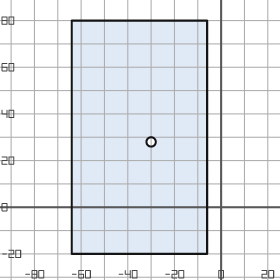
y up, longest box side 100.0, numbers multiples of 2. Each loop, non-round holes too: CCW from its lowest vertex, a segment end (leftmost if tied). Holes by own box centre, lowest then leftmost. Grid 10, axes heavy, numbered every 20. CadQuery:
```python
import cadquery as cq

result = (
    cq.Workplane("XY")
    .moveTo(-64.0, -20.0)
    .lineTo(-6.0, -20.0)
    .lineTo(-6.0, 80.0)
    .lineTo(-64.0, 80.0)
    .close()
    .moveTo(-30.0, 28.0)
    .circle(2.0)
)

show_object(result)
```